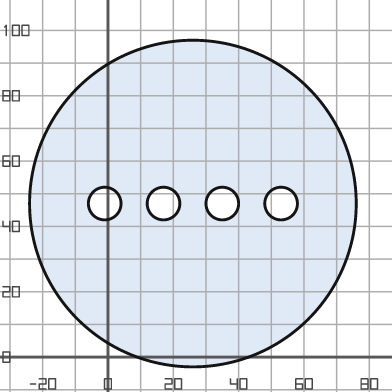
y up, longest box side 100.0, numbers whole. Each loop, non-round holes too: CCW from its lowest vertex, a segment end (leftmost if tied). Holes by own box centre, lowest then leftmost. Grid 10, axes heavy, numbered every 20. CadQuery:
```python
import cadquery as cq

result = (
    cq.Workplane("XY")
    .moveTo(26.0, 47.0)
    .circle(50.0)
    .moveTo(-1.0, 47.0)
    .circle(5.0)
    .moveTo(17.0, 47.0)
    .circle(5.0)
    .moveTo(35.0, 47.0)
    .circle(5.0)
    .moveTo(53.0, 47.0)
    .circle(5.0)
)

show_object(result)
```